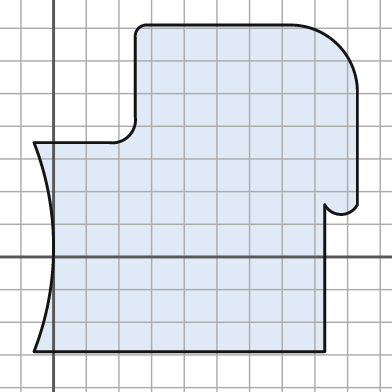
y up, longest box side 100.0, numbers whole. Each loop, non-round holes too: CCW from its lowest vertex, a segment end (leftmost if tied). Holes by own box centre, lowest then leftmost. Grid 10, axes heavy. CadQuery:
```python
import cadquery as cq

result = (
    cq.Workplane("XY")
    .moveTo(-6.0, -29.0)
    .lineTo(83.0, -29.0)
    .lineTo(83.0, 16.0)
    .threePointArc((88.0, 13.0), (93.0, 16.0))
    .lineTo(93.0, 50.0)
    .threePointArc((87.0, 65.0), (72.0, 71.0))
    .lineTo(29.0, 71.0)
    .threePointArc((26.0, 70.0), (25.0, 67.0))
    .lineTo(25.0, 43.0)
    .threePointArc((23.0, 37.0), (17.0, 35.0))
    .lineTo(-6.0, 35.0)
    .threePointArc((0.0, 3.0), (-6.0, -29.0))
    .close()
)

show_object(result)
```